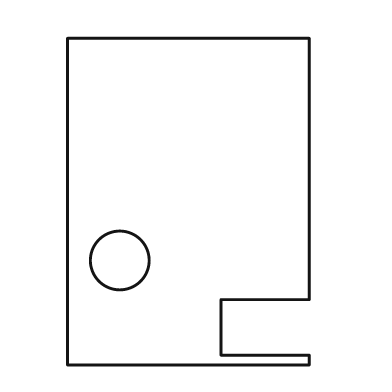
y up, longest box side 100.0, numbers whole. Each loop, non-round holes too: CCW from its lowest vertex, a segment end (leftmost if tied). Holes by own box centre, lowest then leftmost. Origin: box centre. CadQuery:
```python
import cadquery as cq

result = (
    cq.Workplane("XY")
    .moveTo(-37.0, -50.0)
    .lineTo(37.0, -50.0)
    .lineTo(37.0, -47.0)
    .lineTo(10.0, -47.0)
    .lineTo(10.0, -30.0)
    .lineTo(37.0, -30.0)
    .lineTo(37.0, 50.0)
    .lineTo(-37.0, 50.0)
    .close()
    .moveTo(-21.0, -18.0)
    .circle(9.0)
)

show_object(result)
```